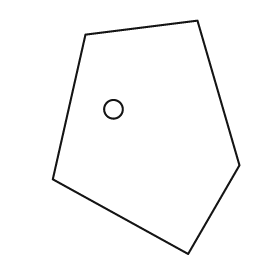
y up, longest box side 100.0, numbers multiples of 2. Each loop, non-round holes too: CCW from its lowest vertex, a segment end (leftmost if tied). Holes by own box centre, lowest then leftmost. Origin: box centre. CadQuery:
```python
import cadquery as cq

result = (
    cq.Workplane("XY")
    .moveTo(18.0, -50.0)
    .lineTo(40.0, -12.0)
    .lineTo(22.0, 50.0)
    .lineTo(-26.0, 44.0)
    .lineTo(-40.0, -18.0)
    .close()
    .moveTo(-14.0, 12.0)
    .circle(4.0)
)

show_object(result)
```